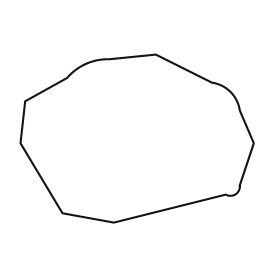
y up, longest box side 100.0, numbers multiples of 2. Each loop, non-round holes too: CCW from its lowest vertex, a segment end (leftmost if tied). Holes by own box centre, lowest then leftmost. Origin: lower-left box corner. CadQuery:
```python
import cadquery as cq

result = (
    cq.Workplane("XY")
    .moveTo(40.0, 0.0)
    .lineTo(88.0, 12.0)
    .threePointArc((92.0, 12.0), (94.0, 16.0))
    .lineTo(100.0, 34.0)
    .lineTo(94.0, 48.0)
    .threePointArc((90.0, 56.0), (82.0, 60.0))
    .lineTo(58.0, 72.0)
    .lineTo(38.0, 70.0)
    .threePointArc((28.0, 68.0), (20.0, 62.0))
    .lineTo(2.0, 52.0)
    .lineTo(0.0, 34.0)
    .lineTo(18.0, 4.0)
    .close()
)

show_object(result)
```